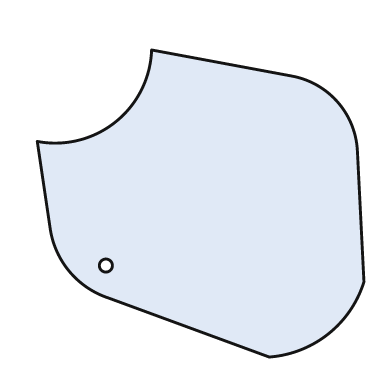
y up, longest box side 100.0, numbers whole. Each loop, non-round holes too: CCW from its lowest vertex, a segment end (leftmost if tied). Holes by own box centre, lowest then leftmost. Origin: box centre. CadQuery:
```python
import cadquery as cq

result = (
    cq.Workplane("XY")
    .moveTo(21.0, -47.0)
    .threePointArc((39.0, -40.0), (50.0, -24.0))
    .lineTo(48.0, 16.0)
    .threePointArc((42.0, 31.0), (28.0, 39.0))
    .lineTo(-15.0, 47.0)
    .threePointArc((-26.0, 25.0), (-50.0, 19.0))
    .lineTo(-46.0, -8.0)
    .threePointArc((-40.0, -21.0), (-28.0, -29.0))
    .close()
    .moveTo(-29.0, -19.0)
    .circle(2.0)
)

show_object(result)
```